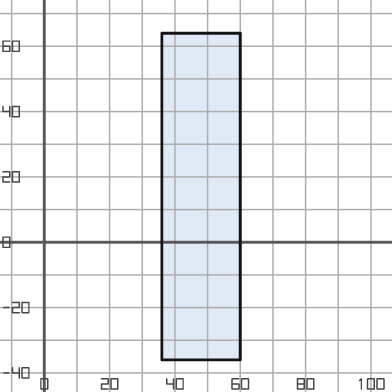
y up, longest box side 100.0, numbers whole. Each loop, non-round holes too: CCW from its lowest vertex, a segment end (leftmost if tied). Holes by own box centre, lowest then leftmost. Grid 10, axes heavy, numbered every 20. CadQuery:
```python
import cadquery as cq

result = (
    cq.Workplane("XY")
    .moveTo(36.0, -36.0)
    .lineTo(60.0, -36.0)
    .lineTo(60.0, 64.0)
    .lineTo(36.0, 64.0)
    .close()
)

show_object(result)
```